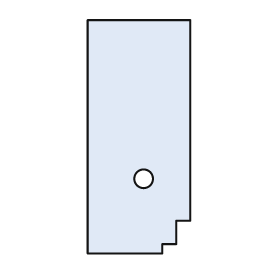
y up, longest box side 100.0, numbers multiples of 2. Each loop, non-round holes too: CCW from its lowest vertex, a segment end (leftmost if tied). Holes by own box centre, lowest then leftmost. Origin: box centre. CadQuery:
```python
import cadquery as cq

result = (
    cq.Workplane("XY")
    .moveTo(-22.0, -50.0)
    .lineTo(10.0, -50.0)
    .lineTo(10.0, -46.0)
    .lineTo(16.0, -46.0)
    .lineTo(16.0, -36.0)
    .lineTo(22.0, -36.0)
    .lineTo(22.0, 50.0)
    .lineTo(-22.0, 50.0)
    .close()
    .moveTo(2.0, -18.0)
    .circle(4.0)
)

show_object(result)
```